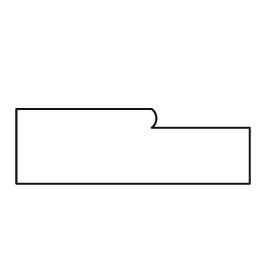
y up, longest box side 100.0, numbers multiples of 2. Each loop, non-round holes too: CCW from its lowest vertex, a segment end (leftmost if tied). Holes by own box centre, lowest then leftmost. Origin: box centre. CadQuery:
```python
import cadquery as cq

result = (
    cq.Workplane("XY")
    .moveTo(-50.0, -16.0)
    .lineTo(50.0, -16.0)
    .lineTo(50.0, 8.0)
    .lineTo(8.0, 8.0)
    .threePointArc((10.0, 12.0), (8.0, 16.0))
    .lineTo(-50.0, 16.0)
    .close()
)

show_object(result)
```